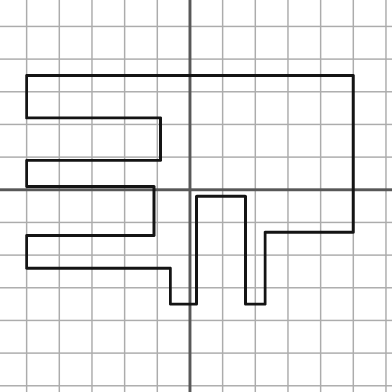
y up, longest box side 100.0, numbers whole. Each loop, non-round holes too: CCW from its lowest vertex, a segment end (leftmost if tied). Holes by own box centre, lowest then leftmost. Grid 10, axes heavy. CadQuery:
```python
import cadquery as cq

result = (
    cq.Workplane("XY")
    .moveTo(-6.0, -35.0)
    .lineTo(2.0, -35.0)
    .lineTo(2.0, -2.0)
    .lineTo(17.0, -2.0)
    .lineTo(17.0, -35.0)
    .lineTo(23.0, -35.0)
    .lineTo(23.0, -13.0)
    .lineTo(50.0, -13.0)
    .lineTo(50.0, 35.0)
    .lineTo(-50.0, 35.0)
    .lineTo(-50.0, 22.0)
    .lineTo(-9.0, 22.0)
    .lineTo(-9.0, 9.0)
    .lineTo(-50.0, 9.0)
    .lineTo(-50.0, 1.0)
    .lineTo(-11.0, 1.0)
    .lineTo(-11.0, -14.0)
    .lineTo(-50.0, -14.0)
    .lineTo(-50.0, -24.0)
    .lineTo(-6.0, -24.0)
    .close()
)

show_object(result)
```